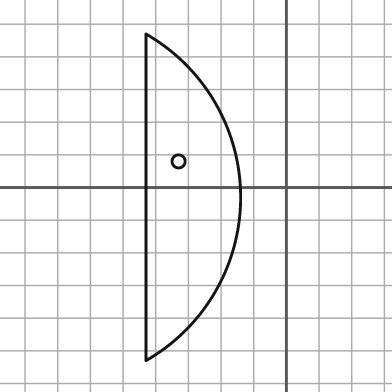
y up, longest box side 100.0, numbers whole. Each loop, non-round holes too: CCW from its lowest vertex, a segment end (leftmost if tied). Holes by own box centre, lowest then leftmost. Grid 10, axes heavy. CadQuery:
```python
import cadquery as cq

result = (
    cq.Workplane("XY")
    .moveTo(-43.0, -53.0)
    .threePointArc((-14.0, -3.0), (-43.0, 47.0))
    .close()
    .moveTo(-33.0, 8.0)
    .circle(2.0)
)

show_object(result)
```